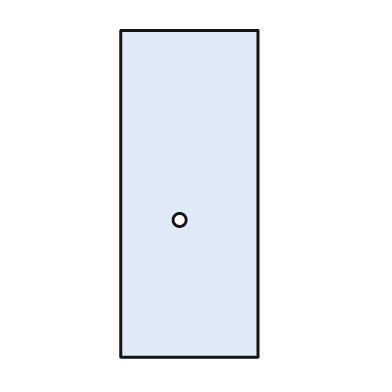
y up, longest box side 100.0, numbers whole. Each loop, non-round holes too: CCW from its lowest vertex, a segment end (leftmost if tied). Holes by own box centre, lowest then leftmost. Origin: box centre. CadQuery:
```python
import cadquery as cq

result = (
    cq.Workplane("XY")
    .moveTo(-21.0, -50.0)
    .lineTo(21.0, -50.0)
    .lineTo(21.0, 50.0)
    .lineTo(-21.0, 50.0)
    .close()
    .moveTo(-3.0, -8.0)
    .circle(2.0)
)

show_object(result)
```